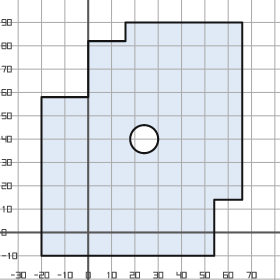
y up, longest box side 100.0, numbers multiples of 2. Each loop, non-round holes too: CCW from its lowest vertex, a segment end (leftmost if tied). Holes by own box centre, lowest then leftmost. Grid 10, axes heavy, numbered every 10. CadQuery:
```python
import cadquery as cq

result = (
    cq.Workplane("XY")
    .moveTo(-20.0, -10.0)
    .lineTo(54.0, -10.0)
    .lineTo(54.0, 14.0)
    .lineTo(66.0, 14.0)
    .lineTo(66.0, 90.0)
    .lineTo(16.0, 90.0)
    .lineTo(16.0, 82.0)
    .lineTo(0.0, 82.0)
    .lineTo(0.0, 58.0)
    .lineTo(-20.0, 58.0)
    .close()
    .moveTo(24.0, 40.0)
    .circle(6.0)
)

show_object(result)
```